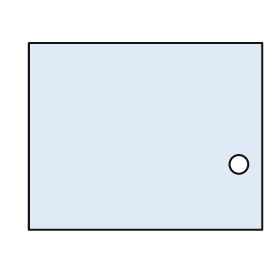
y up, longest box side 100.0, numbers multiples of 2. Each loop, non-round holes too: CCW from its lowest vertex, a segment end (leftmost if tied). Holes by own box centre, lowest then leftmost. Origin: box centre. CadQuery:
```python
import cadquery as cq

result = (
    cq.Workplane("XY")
    .moveTo(-50.0, -40.0)
    .lineTo(50.0, -40.0)
    .lineTo(50.0, 40.0)
    .lineTo(-50.0, 40.0)
    .close()
    .moveTo(40.0, -12.0)
    .circle(4.0)
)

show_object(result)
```